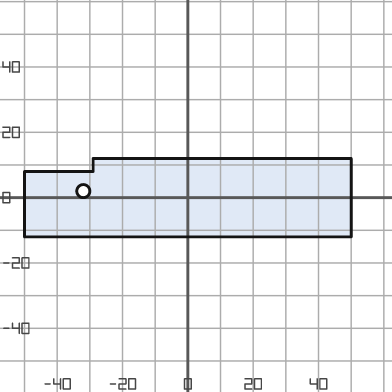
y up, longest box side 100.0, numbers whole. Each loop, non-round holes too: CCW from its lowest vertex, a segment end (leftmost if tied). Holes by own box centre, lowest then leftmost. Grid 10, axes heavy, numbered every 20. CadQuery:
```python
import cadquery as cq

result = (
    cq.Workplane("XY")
    .moveTo(-50.0, -12.0)
    .lineTo(50.0, -12.0)
    .lineTo(50.0, 12.0)
    .lineTo(-29.0, 12.0)
    .lineTo(-29.0, 8.0)
    .lineTo(-50.0, 8.0)
    .close()
    .moveTo(-32.0, 2.0)
    .circle(2.0)
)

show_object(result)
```